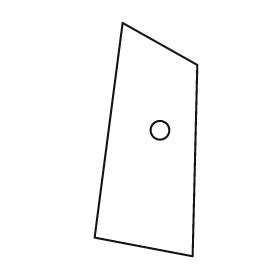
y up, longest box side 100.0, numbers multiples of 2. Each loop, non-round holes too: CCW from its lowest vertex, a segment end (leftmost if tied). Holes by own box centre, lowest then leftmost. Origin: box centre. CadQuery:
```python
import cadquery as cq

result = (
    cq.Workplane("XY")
    .moveTo(20.0, -50.0)
    .lineTo(22.0, 32.0)
    .lineTo(-10.0, 50.0)
    .lineTo(-22.0, -42.0)
    .close()
    .moveTo(6.0, 4.0)
    .circle(4.0)
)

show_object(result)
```